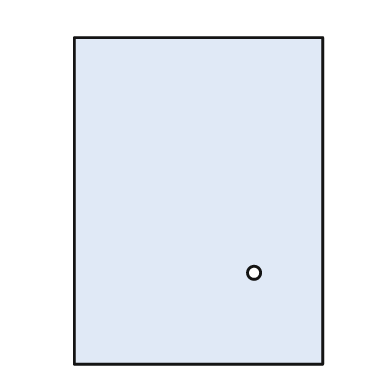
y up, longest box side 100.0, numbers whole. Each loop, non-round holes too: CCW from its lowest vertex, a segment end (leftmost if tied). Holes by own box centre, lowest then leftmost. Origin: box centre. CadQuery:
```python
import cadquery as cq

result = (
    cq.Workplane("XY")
    .moveTo(-38.0, -50.0)
    .lineTo(38.0, -50.0)
    .lineTo(38.0, 50.0)
    .lineTo(-38.0, 50.0)
    .close()
    .moveTo(17.0, -22.0)
    .circle(2.0)
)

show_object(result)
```